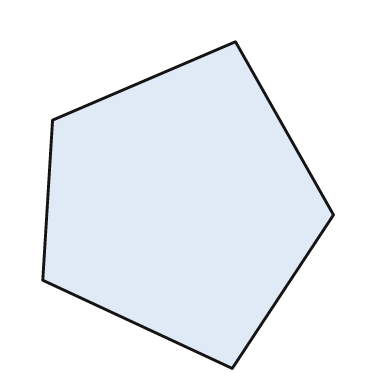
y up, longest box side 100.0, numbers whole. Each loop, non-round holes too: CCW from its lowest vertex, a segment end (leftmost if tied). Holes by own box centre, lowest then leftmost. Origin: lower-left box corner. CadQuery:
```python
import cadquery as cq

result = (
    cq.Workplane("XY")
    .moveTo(58.0, 0.0)
    .lineTo(89.0, 47.0)
    .lineTo(59.0, 100.0)
    .lineTo(3.0, 76.0)
    .lineTo(0.0, 27.0)
    .close()
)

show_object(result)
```